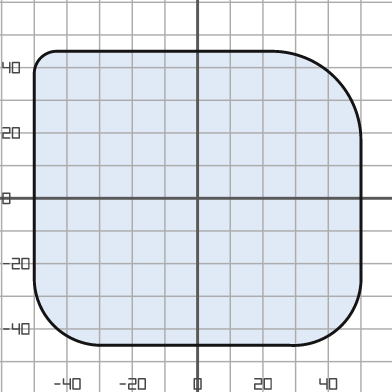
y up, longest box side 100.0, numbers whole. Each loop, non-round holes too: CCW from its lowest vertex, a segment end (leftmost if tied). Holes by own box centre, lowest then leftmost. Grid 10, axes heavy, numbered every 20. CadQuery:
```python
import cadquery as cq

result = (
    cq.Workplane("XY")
    .moveTo(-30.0, -45.0)
    .lineTo(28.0, -45.0)
    .threePointArc((44.0, -39.0), (50.0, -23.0))
    .lineTo(50.0, 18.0)
    .threePointArc((42.0, 37.0), (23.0, 45.0))
    .lineTo(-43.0, 45.0)
    .threePointArc((-48.0, 43.0), (-50.0, 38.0))
    .lineTo(-50.0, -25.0)
    .threePointArc((-44.0, -39.0), (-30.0, -45.0))
    .close()
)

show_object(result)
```